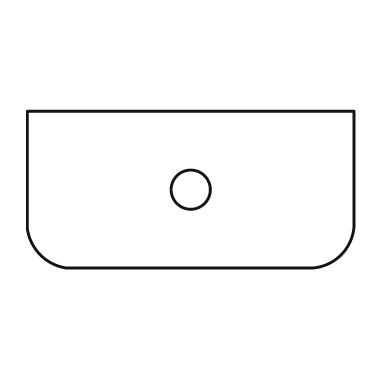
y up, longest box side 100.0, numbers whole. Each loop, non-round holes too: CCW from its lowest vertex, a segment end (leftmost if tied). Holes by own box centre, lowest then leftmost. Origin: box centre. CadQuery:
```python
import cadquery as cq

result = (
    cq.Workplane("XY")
    .moveTo(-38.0, -24.0)
    .lineTo(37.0, -24.0)
    .threePointArc((46.0, -20.0), (50.0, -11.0))
    .lineTo(50.0, 24.0)
    .lineTo(-50.0, 24.0)
    .lineTo(-50.0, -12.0)
    .threePointArc((-46.0, -20.0), (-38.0, -24.0))
    .close()
    .moveTo(0.0, 0.0)
    .circle(6.0)
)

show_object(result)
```